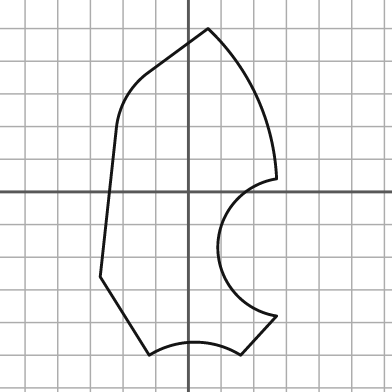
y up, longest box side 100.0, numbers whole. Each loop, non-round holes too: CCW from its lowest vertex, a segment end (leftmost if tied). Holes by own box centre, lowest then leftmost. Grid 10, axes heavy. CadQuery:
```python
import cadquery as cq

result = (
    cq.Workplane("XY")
    .moveTo(-12.0, -50.0)
    .threePointArc((2.0, -46.0), (16.0, -50.0))
    .lineTo(27.0, -38.0)
    .threePointArc((9.0, -17.0), (27.0, 4.0))
    .threePointArc((21.0, 29.0), (6.0, 50.0))
    .lineTo(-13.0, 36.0)
    .threePointArc((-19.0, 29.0), (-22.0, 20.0))
    .lineTo(-27.0, -26.0)
    .close()
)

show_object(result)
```